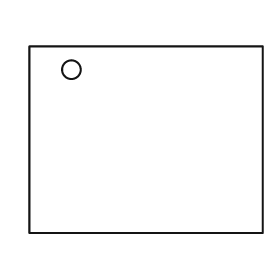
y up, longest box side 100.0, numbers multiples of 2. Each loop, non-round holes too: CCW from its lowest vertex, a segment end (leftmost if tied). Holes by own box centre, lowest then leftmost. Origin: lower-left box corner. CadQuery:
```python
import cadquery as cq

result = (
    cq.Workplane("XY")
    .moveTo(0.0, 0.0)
    .lineTo(100.0, 0.0)
    .lineTo(100.0, 80.0)
    .lineTo(0.0, 80.0)
    .close()
    .moveTo(18.0, 70.0)
    .circle(4.0)
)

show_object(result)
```